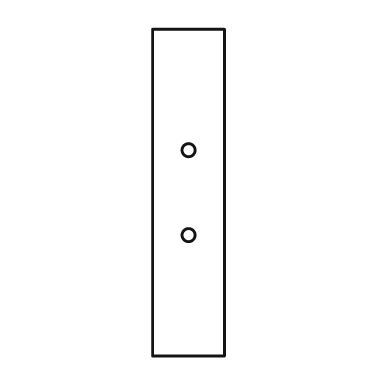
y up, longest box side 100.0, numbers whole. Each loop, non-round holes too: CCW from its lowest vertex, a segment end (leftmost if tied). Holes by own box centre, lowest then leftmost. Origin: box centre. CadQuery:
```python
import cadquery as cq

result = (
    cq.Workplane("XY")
    .moveTo(-11.0, -50.0)
    .lineTo(11.0, -50.0)
    .lineTo(11.0, 50.0)
    .lineTo(-11.0, 50.0)
    .close()
    .moveTo(0.0, -13.0)
    .circle(2.0)
    .moveTo(0.0, 13.0)
    .circle(2.0)
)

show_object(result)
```